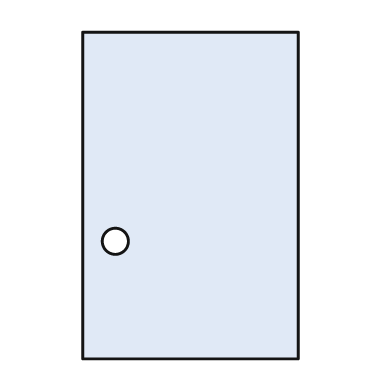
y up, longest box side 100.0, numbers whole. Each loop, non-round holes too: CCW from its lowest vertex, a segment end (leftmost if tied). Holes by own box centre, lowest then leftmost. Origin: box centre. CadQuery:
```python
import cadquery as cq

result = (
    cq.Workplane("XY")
    .moveTo(-33.0, -50.0)
    .lineTo(33.0, -50.0)
    .lineTo(33.0, 50.0)
    .lineTo(-33.0, 50.0)
    .close()
    .moveTo(-23.0, -14.0)
    .circle(4.0)
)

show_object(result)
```